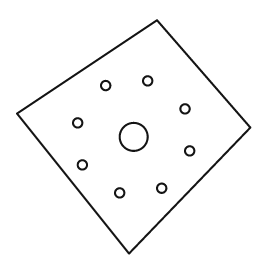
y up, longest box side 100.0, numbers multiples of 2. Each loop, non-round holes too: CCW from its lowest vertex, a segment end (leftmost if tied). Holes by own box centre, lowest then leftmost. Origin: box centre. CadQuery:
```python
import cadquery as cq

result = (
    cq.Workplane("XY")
    .moveTo(-2.0, -50.0)
    .lineTo(50.0, 4.0)
    .lineTo(10.0, 50.0)
    .lineTo(-50.0, 10.0)
    .close()
    .moveTo(-6.0, -24.0)
    .circle(2.0)
    .moveTo(12.0, -22.0)
    .circle(2.0)
    .moveTo(-22.0, -12.0)
    .circle(2.0)
    .moveTo(24.0, -6.0)
    .circle(2.0)
    .moveTo(0.0, 0.0)
    .circle(6.0)
    .moveTo(-24.0, 6.0)
    .circle(2.0)
    .moveTo(22.0, 12.0)
    .circle(2.0)
    .moveTo(-12.0, 22.0)
    .circle(2.0)
    .moveTo(6.0, 24.0)
    .circle(2.0)
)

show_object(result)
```